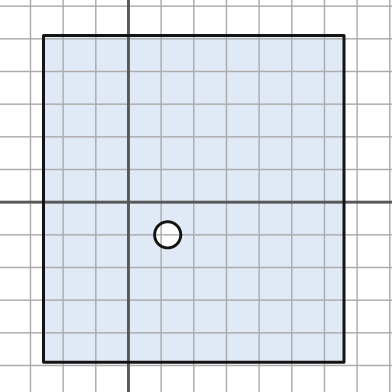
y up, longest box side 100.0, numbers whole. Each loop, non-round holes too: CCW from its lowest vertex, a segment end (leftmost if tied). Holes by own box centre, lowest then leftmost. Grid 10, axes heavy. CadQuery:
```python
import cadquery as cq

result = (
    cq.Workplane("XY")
    .moveTo(-26.0, -49.0)
    .lineTo(66.0, -49.0)
    .lineTo(66.0, 51.0)
    .lineTo(-26.0, 51.0)
    .close()
    .moveTo(12.0, -10.0)
    .circle(4.0)
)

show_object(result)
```